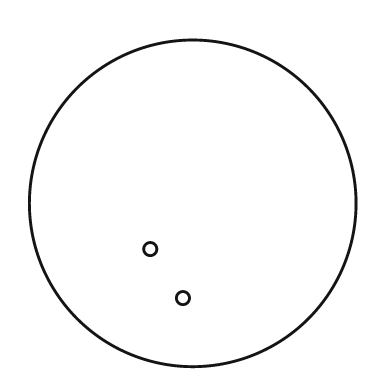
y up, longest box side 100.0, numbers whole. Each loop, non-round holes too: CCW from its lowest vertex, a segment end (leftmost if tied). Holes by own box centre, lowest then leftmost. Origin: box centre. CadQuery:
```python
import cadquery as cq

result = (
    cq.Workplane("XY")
    .moveTo(0.0, 0.0)
    .circle(50.0)
    .moveTo(-3.0, -29.0)
    .circle(2.0)
    .moveTo(-13.0, -14.0)
    .circle(2.0)
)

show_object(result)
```